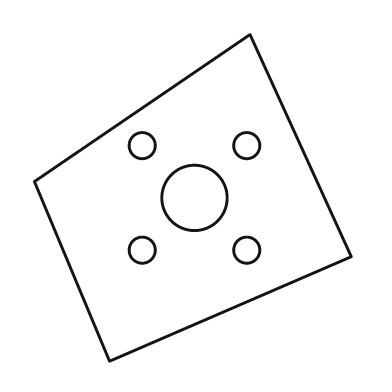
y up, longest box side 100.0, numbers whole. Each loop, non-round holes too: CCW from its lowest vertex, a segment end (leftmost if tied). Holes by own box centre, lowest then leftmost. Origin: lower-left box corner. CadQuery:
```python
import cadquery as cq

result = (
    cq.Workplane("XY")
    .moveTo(23.0, 0.0)
    .lineTo(97.0, 32.0)
    .lineTo(66.0, 100.0)
    .lineTo(0.0, 55.0)
    .close()
    .moveTo(33.0, 34.0)
    .circle(4.0)
    .moveTo(65.0, 34.0)
    .circle(4.0)
    .moveTo(49.0, 50.0)
    .circle(10.0)
    .moveTo(33.0, 66.0)
    .circle(4.0)
    .moveTo(65.0, 66.0)
    .circle(4.0)
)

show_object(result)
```